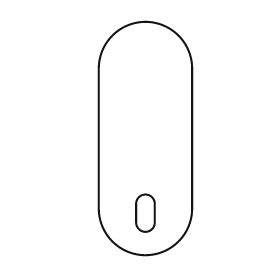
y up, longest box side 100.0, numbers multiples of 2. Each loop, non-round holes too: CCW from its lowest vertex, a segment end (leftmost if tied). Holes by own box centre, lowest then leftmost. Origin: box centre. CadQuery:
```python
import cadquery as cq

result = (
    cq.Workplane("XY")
    .moveTo(-20.0, -30.0)
    .threePointArc((0.0, -50.0), (20.0, -30.0))
    .lineTo(20.0, 30.0)
    .threePointArc((0.0, 50.0), (-20.0, 30.0))
    .close()
    .moveTo(-4.0, -36.0)
    .threePointArc((0.0, -40.0), (4.0, -36.0))
    .lineTo(4.0, -28.0)
    .threePointArc((0.0, -24.0), (-4.0, -28.0))
    .close()
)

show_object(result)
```